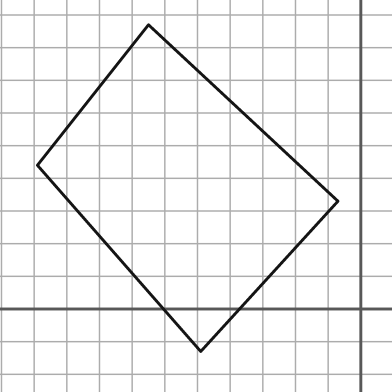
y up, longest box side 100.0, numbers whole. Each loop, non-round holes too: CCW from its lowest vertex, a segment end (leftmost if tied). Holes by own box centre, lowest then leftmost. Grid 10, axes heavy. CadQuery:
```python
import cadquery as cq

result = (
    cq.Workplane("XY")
    .moveTo(-49.0, -13.0)
    .lineTo(-7.0, 33.0)
    .lineTo(-65.0, 87.0)
    .lineTo(-99.0, 44.0)
    .close()
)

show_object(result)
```